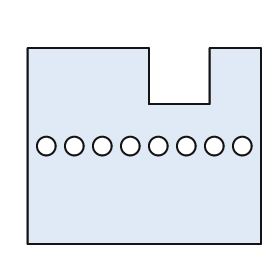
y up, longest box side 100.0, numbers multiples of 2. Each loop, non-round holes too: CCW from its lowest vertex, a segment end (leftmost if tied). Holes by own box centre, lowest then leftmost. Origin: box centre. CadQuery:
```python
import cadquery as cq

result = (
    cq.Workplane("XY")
    .moveTo(-50.0, -42.0)
    .lineTo(50.0, -42.0)
    .lineTo(50.0, 42.0)
    .lineTo(28.0, 42.0)
    .lineTo(28.0, 18.0)
    .lineTo(2.0, 18.0)
    .lineTo(2.0, 42.0)
    .lineTo(-50.0, 42.0)
    .close()
    .moveTo(-42.0, 0.0)
    .circle(4.0)
    .moveTo(-30.0, 0.0)
    .circle(4.0)
    .moveTo(-18.0, 0.0)
    .circle(4.0)
    .moveTo(-6.0, 0.0)
    .circle(4.0)
    .moveTo(6.0, 0.0)
    .circle(4.0)
    .moveTo(18.0, 0.0)
    .circle(4.0)
    .moveTo(30.0, 0.0)
    .circle(4.0)
    .moveTo(42.0, 0.0)
    .circle(4.0)
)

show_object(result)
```